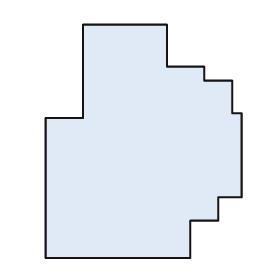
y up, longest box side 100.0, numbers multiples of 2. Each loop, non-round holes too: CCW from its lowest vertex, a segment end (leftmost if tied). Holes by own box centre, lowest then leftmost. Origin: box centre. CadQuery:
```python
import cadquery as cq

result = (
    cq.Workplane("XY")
    .moveTo(-42.0, -50.0)
    .lineTo(20.0, -50.0)
    .lineTo(20.0, -34.0)
    .lineTo(32.0, -34.0)
    .lineTo(32.0, -24.0)
    .lineTo(42.0, -24.0)
    .lineTo(42.0, 12.0)
    .lineTo(38.0, 12.0)
    .lineTo(38.0, 26.0)
    .lineTo(26.0, 26.0)
    .lineTo(26.0, 32.0)
    .lineTo(10.0, 32.0)
    .lineTo(10.0, 50.0)
    .lineTo(-26.0, 50.0)
    .lineTo(-26.0, 10.0)
    .lineTo(-42.0, 10.0)
    .close()
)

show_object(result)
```